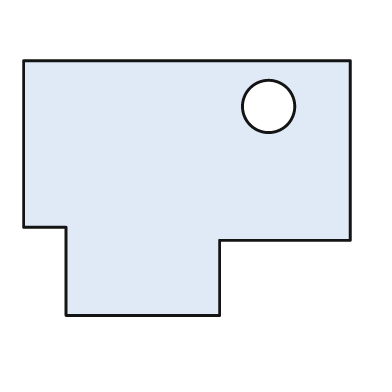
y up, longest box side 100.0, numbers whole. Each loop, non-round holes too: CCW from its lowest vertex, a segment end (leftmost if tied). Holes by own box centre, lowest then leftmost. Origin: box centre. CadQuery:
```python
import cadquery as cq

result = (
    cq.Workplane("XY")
    .moveTo(-37.0, -39.0)
    .lineTo(10.0, -39.0)
    .lineTo(10.0, -16.0)
    .lineTo(50.0, -16.0)
    .lineTo(50.0, 39.0)
    .lineTo(-50.0, 39.0)
    .lineTo(-50.0, -12.0)
    .lineTo(-37.0, -12.0)
    .close()
    .moveTo(25.0, 25.0)
    .circle(8.0)
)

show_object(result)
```